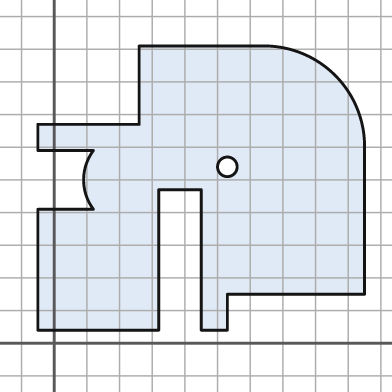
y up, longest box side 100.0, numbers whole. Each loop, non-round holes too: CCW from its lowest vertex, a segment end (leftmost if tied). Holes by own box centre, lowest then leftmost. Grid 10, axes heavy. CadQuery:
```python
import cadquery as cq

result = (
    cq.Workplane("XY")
    .moveTo(-5.0, 4.0)
    .lineTo(32.0, 4.0)
    .lineTo(32.0, 47.0)
    .lineTo(45.0, 47.0)
    .lineTo(45.0, 4.0)
    .lineTo(53.0, 4.0)
    .lineTo(53.0, 15.0)
    .lineTo(95.0, 15.0)
    .lineTo(95.0, 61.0)
    .threePointArc((86.0, 82.0), (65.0, 91.0))
    .lineTo(26.0, 91.0)
    .lineTo(26.0, 67.0)
    .lineTo(-5.0, 67.0)
    .lineTo(-5.0, 59.0)
    .lineTo(12.0, 59.0)
    .threePointArc((9.0, 50.0), (12.0, 41.0))
    .lineTo(-5.0, 41.0)
    .close()
    .moveTo(53.0, 54.0)
    .circle(3.0)
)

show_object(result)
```